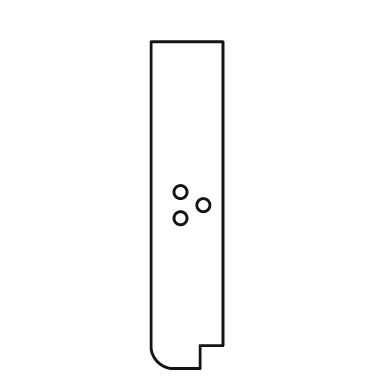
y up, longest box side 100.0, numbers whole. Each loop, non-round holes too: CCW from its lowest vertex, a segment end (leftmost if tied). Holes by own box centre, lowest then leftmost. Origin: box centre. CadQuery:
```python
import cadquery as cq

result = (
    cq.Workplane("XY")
    .moveTo(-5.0, -50.0)
    .lineTo(4.0, -50.0)
    .lineTo(4.0, -43.0)
    .lineTo(11.0, -43.0)
    .lineTo(11.0, 50.0)
    .lineTo(-11.0, 50.0)
    .lineTo(-11.0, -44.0)
    .threePointArc((-9.0, -48.0), (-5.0, -50.0))
    .close()
    .moveTo(-2.0, -4.0)
    .circle(2.0)
    .moveTo(5.0, 0.0)
    .circle(2.0)
    .moveTo(-2.0, 4.0)
    .circle(2.0)
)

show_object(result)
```